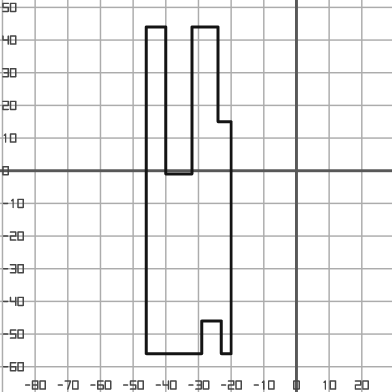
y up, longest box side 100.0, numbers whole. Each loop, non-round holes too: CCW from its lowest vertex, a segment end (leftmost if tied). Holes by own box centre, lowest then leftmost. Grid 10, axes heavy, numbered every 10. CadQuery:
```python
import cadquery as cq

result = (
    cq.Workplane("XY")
    .moveTo(-46.0, -56.0)
    .lineTo(-29.0, -56.0)
    .lineTo(-29.0, -46.0)
    .lineTo(-23.0, -46.0)
    .lineTo(-23.0, -56.0)
    .lineTo(-20.0, -56.0)
    .lineTo(-20.0, 15.0)
    .lineTo(-24.0, 15.0)
    .lineTo(-24.0, 44.0)
    .lineTo(-32.0, 44.0)
    .lineTo(-32.0, -1.0)
    .lineTo(-40.0, -1.0)
    .lineTo(-40.0, 44.0)
    .lineTo(-46.0, 44.0)
    .close()
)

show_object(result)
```